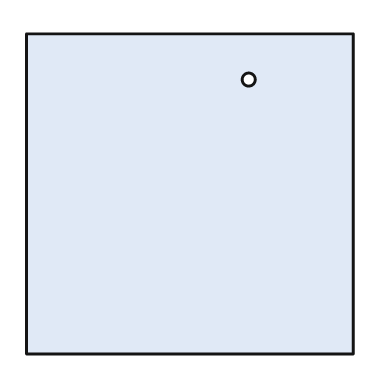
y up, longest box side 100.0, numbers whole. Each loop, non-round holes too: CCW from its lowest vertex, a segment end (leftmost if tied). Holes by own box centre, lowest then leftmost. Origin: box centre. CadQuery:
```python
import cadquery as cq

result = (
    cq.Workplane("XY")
    .moveTo(-50.0, -49.0)
    .lineTo(50.0, -49.0)
    .lineTo(50.0, 49.0)
    .lineTo(-50.0, 49.0)
    .close()
    .moveTo(18.0, 35.0)
    .circle(2.0)
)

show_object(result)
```